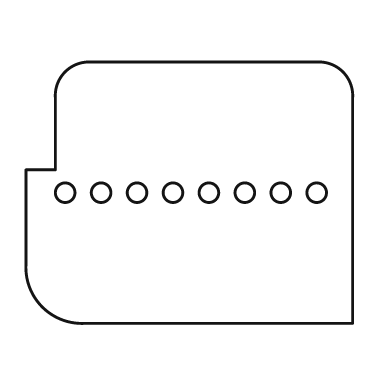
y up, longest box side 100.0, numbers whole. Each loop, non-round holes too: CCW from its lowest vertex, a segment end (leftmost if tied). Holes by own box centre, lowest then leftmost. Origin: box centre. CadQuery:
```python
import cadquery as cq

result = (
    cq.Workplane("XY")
    .moveTo(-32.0, -40.0)
    .lineTo(50.0, -40.0)
    .lineTo(50.0, 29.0)
    .threePointArc((47.0, 37.0), (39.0, 40.0))
    .lineTo(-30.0, 40.0)
    .threePointArc((-38.0, 37.0), (-41.0, 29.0))
    .lineTo(-41.0, 7.0)
    .lineTo(-50.0, 7.0)
    .lineTo(-50.0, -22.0)
    .threePointArc((-45.0, -35.0), (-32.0, -40.0))
    .close()
    .moveTo(-38.0, 0.0)
    .circle(3.0)
    .moveTo(-27.0, 0.0)
    .circle(3.0)
    .moveTo(-16.0, 0.0)
    .circle(3.0)
    .moveTo(-5.0, 0.0)
    .circle(3.0)
    .moveTo(6.0, 0.0)
    .circle(3.0)
    .moveTo(17.0, 0.0)
    .circle(3.0)
    .moveTo(28.0, 0.0)
    .circle(3.0)
    .moveTo(39.0, 0.0)
    .circle(3.0)
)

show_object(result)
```